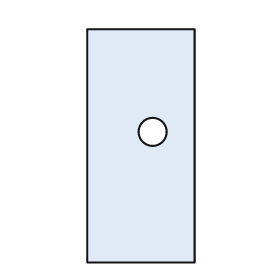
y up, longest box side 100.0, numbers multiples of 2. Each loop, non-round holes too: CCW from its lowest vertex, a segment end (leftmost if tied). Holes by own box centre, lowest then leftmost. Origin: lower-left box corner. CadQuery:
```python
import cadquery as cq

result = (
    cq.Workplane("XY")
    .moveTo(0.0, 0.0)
    .lineTo(46.0, 0.0)
    .lineTo(46.0, 100.0)
    .lineTo(0.0, 100.0)
    .close()
    .moveTo(28.0, 56.0)
    .circle(6.0)
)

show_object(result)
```